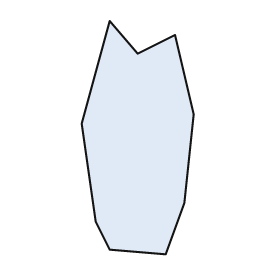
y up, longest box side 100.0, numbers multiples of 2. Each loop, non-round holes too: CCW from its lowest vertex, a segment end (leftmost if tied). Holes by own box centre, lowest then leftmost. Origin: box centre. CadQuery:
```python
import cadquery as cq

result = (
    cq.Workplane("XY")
    .moveTo(12.0, -50.0)
    .lineTo(20.0, -28.0)
    .lineTo(24.0, 10.0)
    .lineTo(16.0, 44.0)
    .lineTo(0.0, 36.0)
    .lineTo(-12.0, 50.0)
    .lineTo(-24.0, 6.0)
    .lineTo(-18.0, -36.0)
    .lineTo(-12.0, -48.0)
    .close()
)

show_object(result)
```